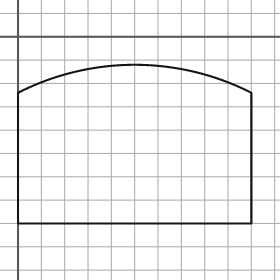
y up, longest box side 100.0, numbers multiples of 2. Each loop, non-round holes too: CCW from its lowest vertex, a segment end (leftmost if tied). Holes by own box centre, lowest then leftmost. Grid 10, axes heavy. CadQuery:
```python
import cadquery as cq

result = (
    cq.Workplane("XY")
    .moveTo(0.0, -80.0)
    .lineTo(100.0, -80.0)
    .lineTo(100.0, -24.0)
    .threePointArc((50.0, -12.0), (0.0, -24.0))
    .close()
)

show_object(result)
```